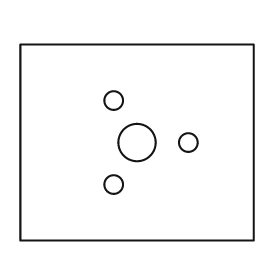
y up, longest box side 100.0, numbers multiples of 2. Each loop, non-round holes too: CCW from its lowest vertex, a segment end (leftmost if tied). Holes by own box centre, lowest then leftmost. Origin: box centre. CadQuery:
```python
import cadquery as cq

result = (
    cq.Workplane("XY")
    .moveTo(-50.0, -42.0)
    .lineTo(50.0, -42.0)
    .lineTo(50.0, 42.0)
    .lineTo(-50.0, 42.0)
    .close()
    .moveTo(-10.0, -18.0)
    .circle(4.0)
    .moveTo(0.0, 0.0)
    .circle(8.0)
    .moveTo(22.0, 0.0)
    .circle(4.0)
    .moveTo(-10.0, 18.0)
    .circle(4.0)
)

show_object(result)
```